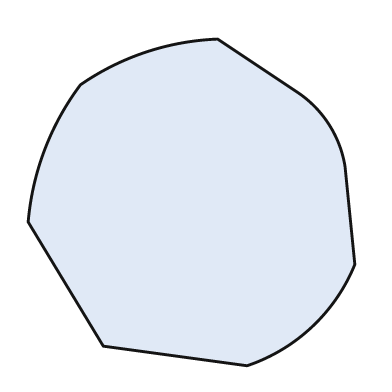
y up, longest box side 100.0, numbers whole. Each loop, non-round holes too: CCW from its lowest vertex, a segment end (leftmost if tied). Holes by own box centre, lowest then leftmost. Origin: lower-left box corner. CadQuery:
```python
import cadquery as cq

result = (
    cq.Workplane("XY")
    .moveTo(67.0, 0.0)
    .threePointArc((87.0, 12.0), (100.0, 31.0))
    .lineTo(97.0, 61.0)
    .threePointArc((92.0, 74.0), (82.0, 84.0))
    .lineTo(58.0, 100.0)
    .threePointArc((36.0, 96.0), (16.0, 86.0))
    .threePointArc((5.0, 66.0), (0.0, 44.0))
    .lineTo(23.0, 6.0)
    .close()
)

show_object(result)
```